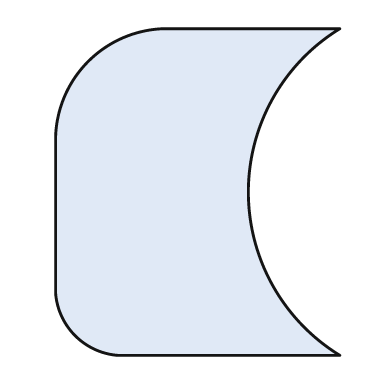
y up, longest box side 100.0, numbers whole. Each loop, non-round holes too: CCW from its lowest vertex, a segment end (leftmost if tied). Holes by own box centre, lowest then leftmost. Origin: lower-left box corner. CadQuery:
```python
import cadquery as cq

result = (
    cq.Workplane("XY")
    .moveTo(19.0, 0.0)
    .lineTo(87.0, 0.0)
    .threePointArc((59.0, 50.0), (87.0, 100.0))
    .lineTo(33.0, 100.0)
    .threePointArc((10.0, 90.0), (0.0, 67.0))
    .lineTo(0.0, 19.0)
    .threePointArc((6.0, 6.0), (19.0, 0.0))
    .close()
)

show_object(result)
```